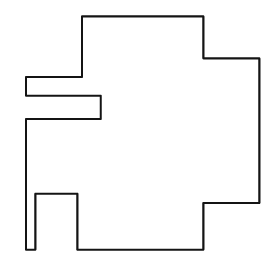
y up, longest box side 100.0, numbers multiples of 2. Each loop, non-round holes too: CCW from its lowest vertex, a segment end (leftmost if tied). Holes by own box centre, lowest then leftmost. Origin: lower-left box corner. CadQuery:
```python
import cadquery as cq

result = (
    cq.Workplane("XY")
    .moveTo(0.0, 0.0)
    .lineTo(4.0, 0.0)
    .lineTo(4.0, 24.0)
    .lineTo(22.0, 24.0)
    .lineTo(22.0, 0.0)
    .lineTo(76.0, 0.0)
    .lineTo(76.0, 20.0)
    .lineTo(100.0, 20.0)
    .lineTo(100.0, 82.0)
    .lineTo(76.0, 82.0)
    .lineTo(76.0, 100.0)
    .lineTo(24.0, 100.0)
    .lineTo(24.0, 74.0)
    .lineTo(0.0, 74.0)
    .lineTo(0.0, 66.0)
    .lineTo(32.0, 66.0)
    .lineTo(32.0, 56.0)
    .lineTo(0.0, 56.0)
    .close()
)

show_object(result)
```